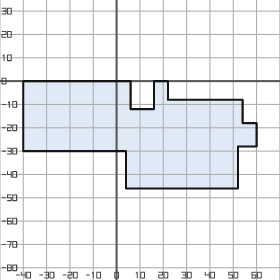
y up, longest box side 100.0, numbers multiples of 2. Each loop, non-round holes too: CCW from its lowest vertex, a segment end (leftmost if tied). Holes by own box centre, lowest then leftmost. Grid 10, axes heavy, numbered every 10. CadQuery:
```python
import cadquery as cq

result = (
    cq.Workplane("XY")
    .moveTo(4.0, -46.0)
    .lineTo(52.0, -46.0)
    .lineTo(52.0, -28.0)
    .lineTo(60.0, -28.0)
    .lineTo(60.0, -18.0)
    .lineTo(54.0, -18.0)
    .lineTo(54.0, -8.0)
    .lineTo(22.0, -8.0)
    .lineTo(22.0, 0.0)
    .lineTo(16.0, 0.0)
    .lineTo(16.0, -12.0)
    .lineTo(6.0, -12.0)
    .lineTo(6.0, 0.0)
    .lineTo(-40.0, 0.0)
    .lineTo(-40.0, -30.0)
    .lineTo(4.0, -30.0)
    .close()
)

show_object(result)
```